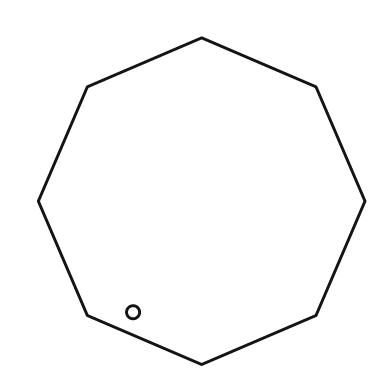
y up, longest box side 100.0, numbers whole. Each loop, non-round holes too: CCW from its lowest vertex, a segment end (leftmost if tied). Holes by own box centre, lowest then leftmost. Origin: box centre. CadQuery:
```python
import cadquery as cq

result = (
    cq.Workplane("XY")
    .moveTo(0.0, -50.0)
    .lineTo(35.0, -35.0)
    .lineTo(50.0, 0.0)
    .lineTo(35.0, 35.0)
    .lineTo(0.0, 50.0)
    .lineTo(-35.0, 35.0)
    .lineTo(-50.0, 0.0)
    .lineTo(-35.0, -35.0)
    .close()
    .moveTo(-21.0, -34.0)
    .circle(2.0)
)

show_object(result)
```